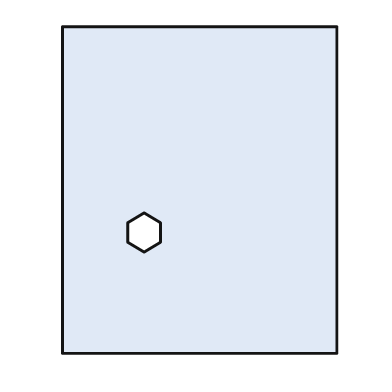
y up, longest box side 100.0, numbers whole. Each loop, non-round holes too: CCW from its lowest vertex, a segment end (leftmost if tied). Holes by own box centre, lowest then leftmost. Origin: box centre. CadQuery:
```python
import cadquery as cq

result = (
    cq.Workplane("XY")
    .moveTo(-42.0, -50.0)
    .lineTo(42.0, -50.0)
    .lineTo(42.0, 50.0)
    .lineTo(-42.0, 50.0)
    .close()
    .moveTo(-17.0, -19.0)
    .lineTo(-12.0, -16.0)
    .lineTo(-12.0, -10.0)
    .lineTo(-17.0, -7.0)
    .lineTo(-22.0, -10.0)
    .lineTo(-22.0, -16.0)
    .close()
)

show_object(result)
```